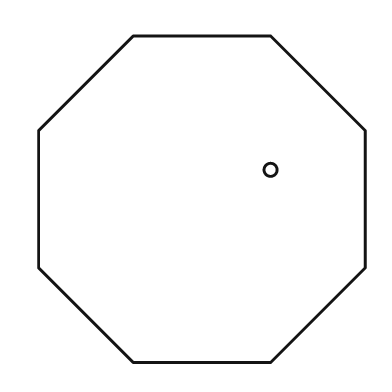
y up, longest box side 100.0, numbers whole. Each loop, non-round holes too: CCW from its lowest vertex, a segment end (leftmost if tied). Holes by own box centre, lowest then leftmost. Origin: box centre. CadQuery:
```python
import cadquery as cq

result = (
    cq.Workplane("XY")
    .moveTo(-21.0, -50.0)
    .lineTo(21.0, -50.0)
    .lineTo(50.0, -21.0)
    .lineTo(50.0, 21.0)
    .lineTo(21.0, 50.0)
    .lineTo(-21.0, 50.0)
    .lineTo(-50.0, 21.0)
    .lineTo(-50.0, -21.0)
    .close()
    .moveTo(21.0, 9.0)
    .circle(2.0)
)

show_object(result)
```